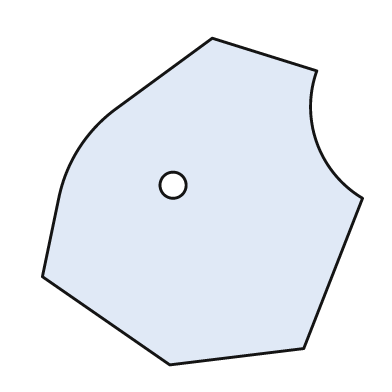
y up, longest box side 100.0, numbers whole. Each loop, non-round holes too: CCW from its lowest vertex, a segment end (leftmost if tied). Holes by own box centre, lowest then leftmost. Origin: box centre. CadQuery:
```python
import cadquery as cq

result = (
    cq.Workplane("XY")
    .moveTo(-10.0, -50.0)
    .lineTo(31.0, -45.0)
    .lineTo(49.0, 1.0)
    .threePointArc((35.0, 18.0), (35.0, 40.0))
    .lineTo(3.0, 50.0)
    .lineTo(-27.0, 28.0)
    .threePointArc((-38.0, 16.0), (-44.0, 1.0))
    .lineTo(-49.0, -23.0)
    .close()
    .moveTo(-9.0, 5.0)
    .circle(4.0)
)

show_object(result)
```